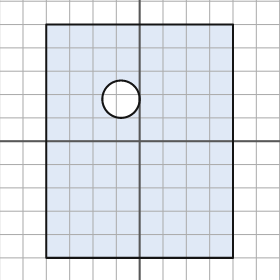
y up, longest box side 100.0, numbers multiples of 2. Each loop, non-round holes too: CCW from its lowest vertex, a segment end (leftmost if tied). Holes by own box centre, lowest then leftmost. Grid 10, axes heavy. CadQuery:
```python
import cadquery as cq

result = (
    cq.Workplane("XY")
    .moveTo(-40.0, -50.0)
    .lineTo(40.0, -50.0)
    .lineTo(40.0, 50.0)
    .lineTo(-40.0, 50.0)
    .close()
    .moveTo(-8.0, 18.0)
    .circle(8.0)
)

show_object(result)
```